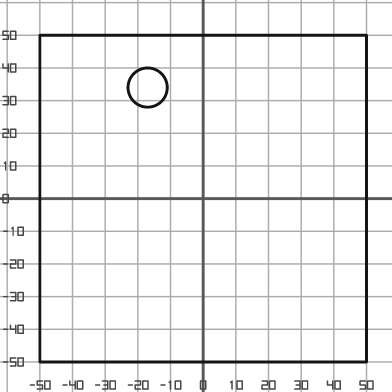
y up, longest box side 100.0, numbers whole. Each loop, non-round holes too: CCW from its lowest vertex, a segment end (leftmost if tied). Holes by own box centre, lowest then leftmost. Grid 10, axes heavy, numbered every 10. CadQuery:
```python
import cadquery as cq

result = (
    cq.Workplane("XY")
    .moveTo(-50.0, -50.0)
    .lineTo(50.0, -50.0)
    .lineTo(50.0, 50.0)
    .lineTo(-50.0, 50.0)
    .close()
    .moveTo(-17.0, 34.0)
    .circle(6.0)
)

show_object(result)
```